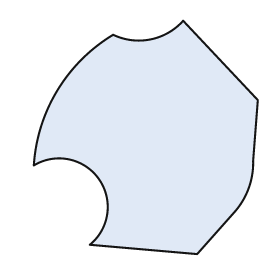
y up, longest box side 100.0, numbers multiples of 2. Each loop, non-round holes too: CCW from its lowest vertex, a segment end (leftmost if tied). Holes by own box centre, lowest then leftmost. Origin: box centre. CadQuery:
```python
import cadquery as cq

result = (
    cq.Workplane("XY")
    .moveTo(22.0, -50.0)
    .lineTo(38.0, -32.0)
    .threePointArc((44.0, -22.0), (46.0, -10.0))
    .lineTo(48.0, 16.0)
    .lineTo(16.0, 50.0)
    .threePointArc((2.0, 42.0), (-14.0, 44.0))
    .threePointArc((-38.0, 20.0), (-48.0, -12.0))
    .threePointArc((-20.0, -18.0), (-24.0, -46.0))
    .close()
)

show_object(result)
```